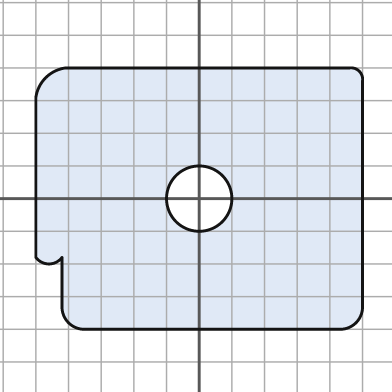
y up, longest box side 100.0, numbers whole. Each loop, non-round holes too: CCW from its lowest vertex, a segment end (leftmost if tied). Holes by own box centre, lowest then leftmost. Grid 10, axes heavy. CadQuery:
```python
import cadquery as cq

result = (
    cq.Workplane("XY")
    .moveTo(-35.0, -40.0)
    .lineTo(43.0, -40.0)
    .threePointArc((48.0, -38.0), (50.0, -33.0))
    .lineTo(50.0, 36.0)
    .threePointArc((49.0, 39.0), (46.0, 40.0))
    .lineTo(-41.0, 40.0)
    .threePointArc((-47.0, 37.0), (-50.0, 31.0))
    .lineTo(-50.0, -18.0)
    .threePointArc((-46.0, -20.0), (-42.0, -18.0))
    .lineTo(-42.0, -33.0)
    .threePointArc((-40.0, -38.0), (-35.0, -40.0))
    .close()
    .moveTo(0.0, 0.0)
    .circle(10.0)
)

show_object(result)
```